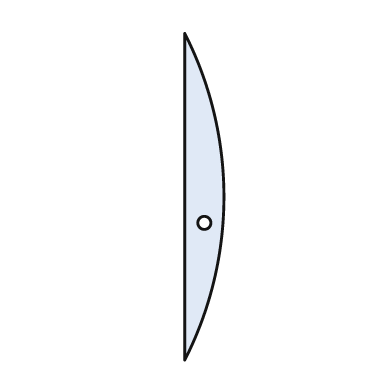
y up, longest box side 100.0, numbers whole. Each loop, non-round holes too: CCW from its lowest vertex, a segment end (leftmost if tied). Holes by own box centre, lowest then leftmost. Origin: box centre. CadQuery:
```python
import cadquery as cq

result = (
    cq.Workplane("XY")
    .moveTo(-6.0, -50.0)
    .threePointArc((6.0, 0.0), (-6.0, 50.0))
    .close()
    .moveTo(0.0, -8.0)
    .circle(2.0)
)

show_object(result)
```